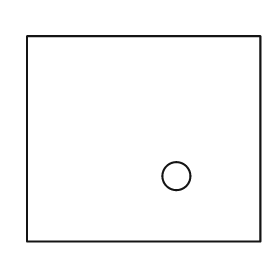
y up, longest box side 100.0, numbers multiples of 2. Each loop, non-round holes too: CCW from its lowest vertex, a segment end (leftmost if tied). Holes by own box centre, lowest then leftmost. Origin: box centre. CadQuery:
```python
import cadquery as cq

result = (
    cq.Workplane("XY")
    .moveTo(-50.0, -44.0)
    .lineTo(50.0, -44.0)
    .lineTo(50.0, 44.0)
    .lineTo(-50.0, 44.0)
    .close()
    .moveTo(14.0, -16.0)
    .circle(6.0)
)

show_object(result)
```